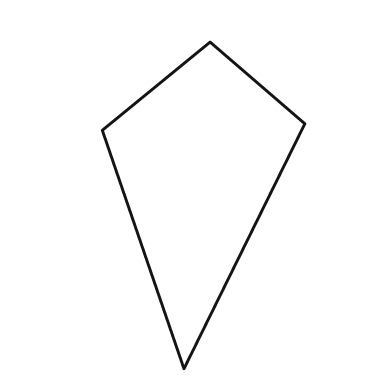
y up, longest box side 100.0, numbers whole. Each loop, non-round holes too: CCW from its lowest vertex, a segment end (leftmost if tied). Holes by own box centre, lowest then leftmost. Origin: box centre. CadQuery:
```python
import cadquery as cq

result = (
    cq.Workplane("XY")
    .moveTo(-6.0, -50.0)
    .lineTo(31.0, 25.0)
    .lineTo(2.0, 50.0)
    .lineTo(-31.0, 23.0)
    .close()
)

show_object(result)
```